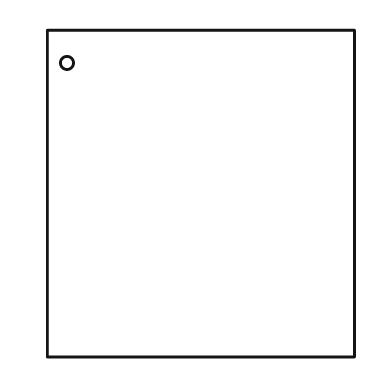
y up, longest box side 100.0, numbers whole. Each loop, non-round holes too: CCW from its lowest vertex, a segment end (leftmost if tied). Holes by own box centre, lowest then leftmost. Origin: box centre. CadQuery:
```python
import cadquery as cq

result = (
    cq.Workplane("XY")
    .moveTo(-47.0, -50.0)
    .lineTo(47.0, -50.0)
    .lineTo(47.0, 50.0)
    .lineTo(-47.0, 50.0)
    .close()
    .moveTo(-41.0, 40.0)
    .circle(2.0)
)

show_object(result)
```